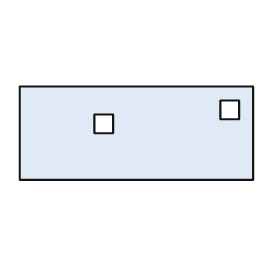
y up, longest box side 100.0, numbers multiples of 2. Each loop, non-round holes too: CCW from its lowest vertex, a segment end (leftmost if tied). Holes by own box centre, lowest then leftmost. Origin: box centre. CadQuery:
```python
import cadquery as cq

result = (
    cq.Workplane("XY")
    .moveTo(-50.0, -20.0)
    .lineTo(50.0, -20.0)
    .lineTo(50.0, 20.0)
    .lineTo(-50.0, 20.0)
    .close()
    .moveTo(-18.0, 0.0)
    .lineTo(-10.0, 0.0)
    .lineTo(-10.0, 8.0)
    .lineTo(-18.0, 8.0)
    .close()
    .moveTo(36.0, 6.0)
    .lineTo(44.0, 6.0)
    .lineTo(44.0, 14.0)
    .lineTo(36.0, 14.0)
    .close()
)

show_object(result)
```